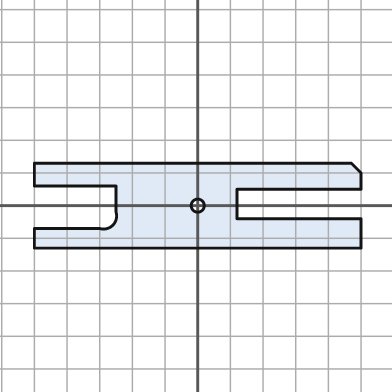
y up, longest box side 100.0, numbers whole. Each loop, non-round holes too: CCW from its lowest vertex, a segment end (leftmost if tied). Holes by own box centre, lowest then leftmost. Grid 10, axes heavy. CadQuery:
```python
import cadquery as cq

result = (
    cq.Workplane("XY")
    .moveTo(-50.0, -13.0)
    .lineTo(50.0, -13.0)
    .lineTo(50.0, -4.0)
    .lineTo(12.0, -4.0)
    .lineTo(12.0, 5.0)
    .lineTo(50.0, 5.0)
    .lineTo(50.0, 10.0)
    .lineTo(47.0, 13.0)
    .lineTo(-50.0, 13.0)
    .lineTo(-50.0, 6.0)
    .lineTo(-25.0, 6.0)
    .lineTo(-25.0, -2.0)
    .threePointArc((-26.0, -6.0), (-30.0, -7.0))
    .lineTo(-50.0, -7.0)
    .close()
    .moveTo(0.0, 0.0)
    .circle(2.0)
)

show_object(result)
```